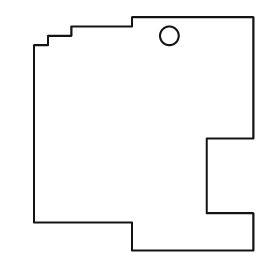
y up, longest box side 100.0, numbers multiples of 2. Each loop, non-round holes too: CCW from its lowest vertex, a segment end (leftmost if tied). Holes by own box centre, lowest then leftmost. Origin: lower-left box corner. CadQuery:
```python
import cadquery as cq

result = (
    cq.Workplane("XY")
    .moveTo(42.0, 0.0)
    .lineTo(94.0, 0.0)
    .lineTo(94.0, 16.0)
    .lineTo(74.0, 16.0)
    .lineTo(74.0, 48.0)
    .lineTo(94.0, 48.0)
    .lineTo(94.0, 100.0)
    .lineTo(42.0, 100.0)
    .lineTo(42.0, 96.0)
    .lineTo(16.0, 96.0)
    .lineTo(16.0, 92.0)
    .lineTo(6.0, 92.0)
    .lineTo(6.0, 88.0)
    .lineTo(0.0, 88.0)
    .lineTo(0.0, 12.0)
    .lineTo(42.0, 12.0)
    .close()
    .moveTo(58.0, 92.0)
    .circle(4.0)
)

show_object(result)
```